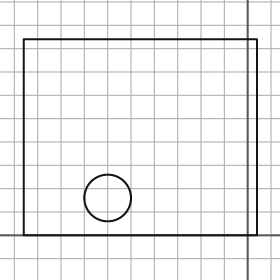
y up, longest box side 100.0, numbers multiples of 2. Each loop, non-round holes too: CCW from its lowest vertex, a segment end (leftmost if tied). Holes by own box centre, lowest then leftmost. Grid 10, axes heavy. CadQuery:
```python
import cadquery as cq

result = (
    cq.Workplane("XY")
    .moveTo(-96.0, 0.0)
    .lineTo(4.0, 0.0)
    .lineTo(4.0, 84.0)
    .lineTo(-96.0, 84.0)
    .close()
    .moveTo(-60.0, 16.0)
    .circle(10.0)
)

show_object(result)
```